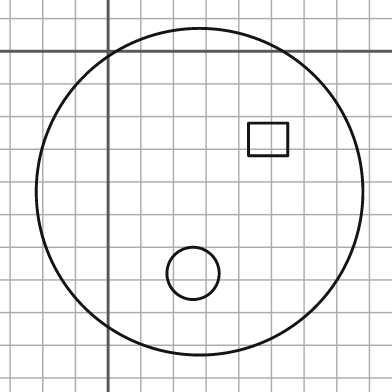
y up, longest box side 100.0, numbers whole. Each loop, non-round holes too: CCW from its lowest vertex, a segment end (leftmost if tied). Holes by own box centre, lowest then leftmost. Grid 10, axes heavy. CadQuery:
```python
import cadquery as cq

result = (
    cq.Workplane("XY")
    .moveTo(28.0, -43.0)
    .circle(50.0)
    .moveTo(26.0, -68.0)
    .circle(8.0)
    .moveTo(43.0, -32.0)
    .lineTo(55.0, -32.0)
    .lineTo(55.0, -22.0)
    .lineTo(43.0, -22.0)
    .close()
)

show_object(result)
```